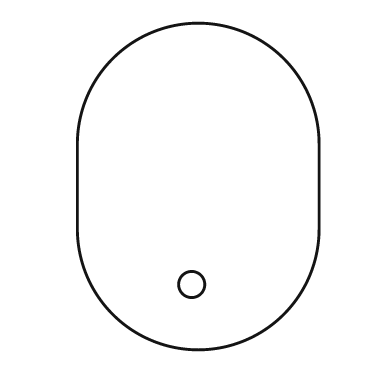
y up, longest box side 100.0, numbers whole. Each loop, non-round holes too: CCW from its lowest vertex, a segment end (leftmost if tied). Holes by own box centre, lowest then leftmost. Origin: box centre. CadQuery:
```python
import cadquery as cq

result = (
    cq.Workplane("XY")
    .moveTo(-37.0, -13.0)
    .threePointArc((0.0, -50.0), (37.0, -13.0))
    .lineTo(37.0, 13.0)
    .threePointArc((0.0, 50.0), (-37.0, 13.0))
    .close()
    .moveTo(-2.0, -30.0)
    .circle(4.0)
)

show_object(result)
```